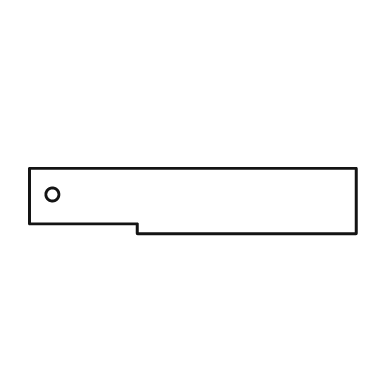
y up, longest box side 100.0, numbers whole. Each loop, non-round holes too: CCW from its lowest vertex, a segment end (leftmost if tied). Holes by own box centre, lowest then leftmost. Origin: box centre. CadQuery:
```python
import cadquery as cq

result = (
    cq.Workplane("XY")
    .moveTo(-17.0, -10.0)
    .lineTo(50.0, -10.0)
    .lineTo(50.0, 10.0)
    .lineTo(-50.0, 10.0)
    .lineTo(-50.0, -7.0)
    .lineTo(-17.0, -7.0)
    .close()
    .moveTo(-43.0, 2.0)
    .circle(2.0)
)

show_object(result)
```